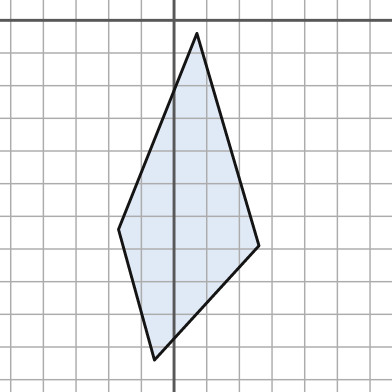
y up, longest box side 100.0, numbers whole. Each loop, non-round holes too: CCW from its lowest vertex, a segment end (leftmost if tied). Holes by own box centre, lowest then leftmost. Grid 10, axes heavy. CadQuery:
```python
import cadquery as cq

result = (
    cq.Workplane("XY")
    .moveTo(-6.0, -104.0)
    .lineTo(26.0, -69.0)
    .lineTo(7.0, -4.0)
    .lineTo(-17.0, -64.0)
    .close()
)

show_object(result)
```